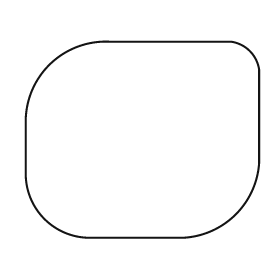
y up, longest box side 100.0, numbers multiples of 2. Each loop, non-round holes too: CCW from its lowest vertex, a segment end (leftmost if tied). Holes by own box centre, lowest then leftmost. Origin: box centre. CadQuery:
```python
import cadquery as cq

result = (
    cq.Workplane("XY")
    .moveTo(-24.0, -42.0)
    .lineTo(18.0, -42.0)
    .threePointArc((40.0, -32.0), (50.0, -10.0))
    .lineTo(50.0, 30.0)
    .threePointArc((46.0, 38.0), (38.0, 42.0))
    .lineTo(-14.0, 42.0)
    .threePointArc((-40.0, 32.0), (-50.0, 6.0))
    .lineTo(-50.0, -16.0)
    .threePointArc((-42.0, -34.0), (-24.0, -42.0))
    .close()
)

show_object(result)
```